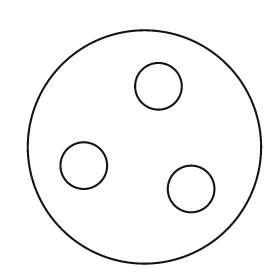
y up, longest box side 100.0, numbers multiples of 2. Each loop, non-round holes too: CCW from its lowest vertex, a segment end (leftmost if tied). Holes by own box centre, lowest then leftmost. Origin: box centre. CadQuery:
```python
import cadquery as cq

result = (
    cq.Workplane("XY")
    .moveTo(0.0, 0.0)
    .circle(50.0)
    .moveTo(20.0, -18.0)
    .circle(10.0)
    .moveTo(-26.0, -8.0)
    .circle(10.0)
    .moveTo(6.0, 26.0)
    .circle(10.0)
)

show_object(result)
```